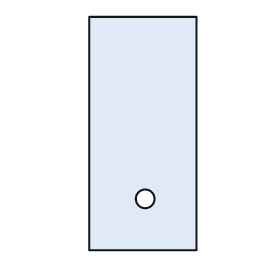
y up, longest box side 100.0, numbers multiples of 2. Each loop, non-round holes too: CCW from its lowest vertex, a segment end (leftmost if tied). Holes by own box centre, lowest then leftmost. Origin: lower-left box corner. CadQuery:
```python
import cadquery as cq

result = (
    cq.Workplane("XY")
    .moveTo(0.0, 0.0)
    .lineTo(46.0, 0.0)
    .lineTo(46.0, 100.0)
    .lineTo(0.0, 100.0)
    .close()
    .moveTo(24.0, 22.0)
    .circle(4.0)
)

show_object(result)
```